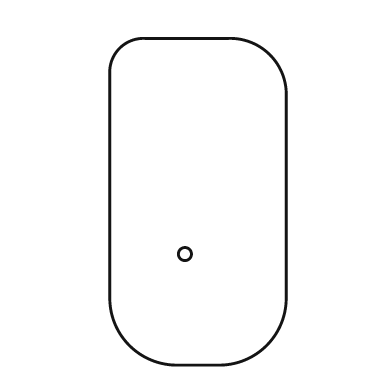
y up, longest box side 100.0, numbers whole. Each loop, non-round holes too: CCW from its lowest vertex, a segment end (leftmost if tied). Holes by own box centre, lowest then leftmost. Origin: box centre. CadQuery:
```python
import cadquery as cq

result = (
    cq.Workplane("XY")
    .moveTo(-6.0, -50.0)
    .lineTo(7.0, -50.0)
    .threePointArc((21.0, -44.0), (27.0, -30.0))
    .lineTo(27.0, 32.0)
    .threePointArc((22.0, 45.0), (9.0, 50.0))
    .lineTo(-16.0, 50.0)
    .threePointArc((-24.0, 47.0), (-27.0, 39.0))
    .lineTo(-27.0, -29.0)
    .threePointArc((-21.0, -44.0), (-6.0, -50.0))
    .close()
    .moveTo(-4.0, -16.0)
    .circle(2.0)
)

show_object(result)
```